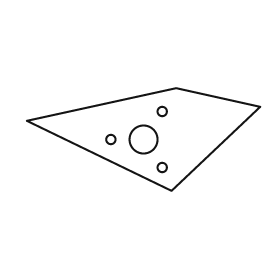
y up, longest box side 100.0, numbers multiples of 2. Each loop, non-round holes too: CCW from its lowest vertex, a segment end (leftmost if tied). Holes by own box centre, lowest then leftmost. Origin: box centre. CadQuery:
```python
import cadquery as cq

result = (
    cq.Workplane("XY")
    .moveTo(12.0, -22.0)
    .lineTo(50.0, 14.0)
    .lineTo(14.0, 22.0)
    .lineTo(-50.0, 8.0)
    .close()
    .moveTo(8.0, -12.0)
    .circle(2.0)
    .moveTo(-14.0, 0.0)
    .circle(2.0)
    .moveTo(0.0, 0.0)
    .circle(6.0)
    .moveTo(8.0, 12.0)
    .circle(2.0)
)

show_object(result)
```